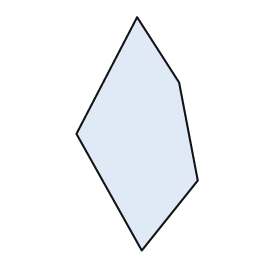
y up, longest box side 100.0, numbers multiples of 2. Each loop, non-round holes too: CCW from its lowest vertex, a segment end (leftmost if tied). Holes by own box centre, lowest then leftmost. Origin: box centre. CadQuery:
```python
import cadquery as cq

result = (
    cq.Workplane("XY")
    .moveTo(2.0, -50.0)
    .lineTo(26.0, -20.0)
    .lineTo(18.0, 22.0)
    .lineTo(0.0, 50.0)
    .lineTo(-26.0, 0.0)
    .close()
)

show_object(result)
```